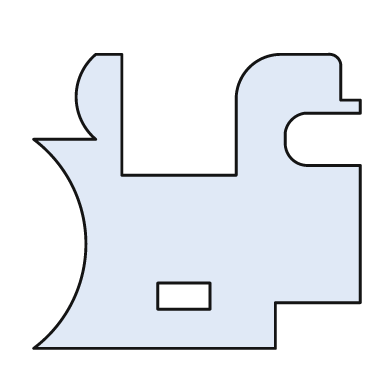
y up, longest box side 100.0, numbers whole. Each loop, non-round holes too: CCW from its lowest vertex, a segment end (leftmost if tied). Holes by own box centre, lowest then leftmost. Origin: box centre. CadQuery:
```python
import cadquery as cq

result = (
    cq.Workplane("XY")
    .moveTo(-50.0, -45.0)
    .lineTo(24.0, -45.0)
    .lineTo(24.0, -31.0)
    .lineTo(50.0, -31.0)
    .lineTo(50.0, 11.0)
    .lineTo(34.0, 11.0)
    .threePointArc((29.0, 13.0), (27.0, 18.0))
    .lineTo(27.0, 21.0)
    .threePointArc((29.0, 25.0), (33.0, 27.0))
    .lineTo(50.0, 27.0)
    .lineTo(50.0, 31.0)
    .lineTo(44.0, 31.0)
    .lineTo(44.0, 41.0)
    .threePointArc((43.0, 44.0), (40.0, 45.0))
    .lineTo(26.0, 45.0)
    .threePointArc((16.0, 41.0), (12.0, 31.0))
    .lineTo(12.0, 8.0)
    .lineTo(-23.0, 8.0)
    .lineTo(-23.0, 45.0)
    .lineTo(-31.0, 45.0)
    .threePointArc((-37.0, 32.0), (-31.0, 19.0))
    .lineTo(-50.0, 19.0)
    .threePointArc((-34.0, -13.0), (-50.0, -45.0))
    .close()
    .moveTo(-12.0, -33.0)
    .lineTo(4.0, -33.0)
    .lineTo(4.0, -25.0)
    .lineTo(-12.0, -25.0)
    .close()
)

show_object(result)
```